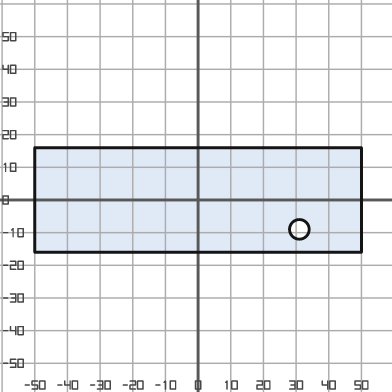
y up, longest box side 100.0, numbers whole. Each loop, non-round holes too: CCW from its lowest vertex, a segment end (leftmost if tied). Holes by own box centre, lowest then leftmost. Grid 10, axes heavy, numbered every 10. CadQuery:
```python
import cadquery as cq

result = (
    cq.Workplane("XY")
    .moveTo(-50.0, -16.0)
    .lineTo(50.0, -16.0)
    .lineTo(50.0, 16.0)
    .lineTo(-50.0, 16.0)
    .close()
    .moveTo(31.0, -9.0)
    .circle(3.0)
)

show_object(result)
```